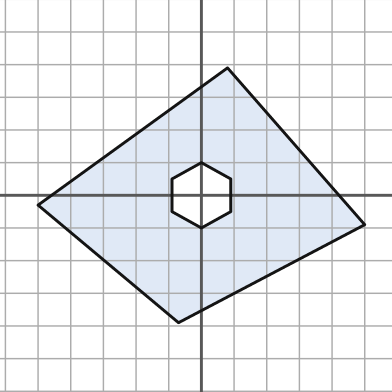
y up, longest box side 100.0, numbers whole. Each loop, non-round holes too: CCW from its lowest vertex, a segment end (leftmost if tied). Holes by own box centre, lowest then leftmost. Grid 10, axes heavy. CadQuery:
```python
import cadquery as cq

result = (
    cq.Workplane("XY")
    .moveTo(-7.0, -39.0)
    .lineTo(50.0, -9.0)
    .lineTo(8.0, 39.0)
    .lineTo(-50.0, -3.0)
    .close()
    .moveTo(0.0, -10.0)
    .lineTo(9.0, -5.0)
    .lineTo(9.0, 5.0)
    .lineTo(0.0, 10.0)
    .lineTo(-9.0, 5.0)
    .lineTo(-9.0, -5.0)
    .close()
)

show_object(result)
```